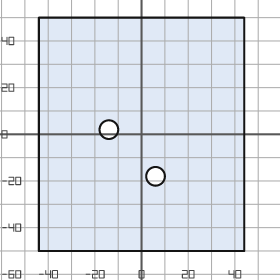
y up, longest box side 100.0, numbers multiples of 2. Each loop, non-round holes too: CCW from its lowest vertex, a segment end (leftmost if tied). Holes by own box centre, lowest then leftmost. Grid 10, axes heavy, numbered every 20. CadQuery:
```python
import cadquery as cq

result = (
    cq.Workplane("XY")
    .moveTo(-44.0, -50.0)
    .lineTo(44.0, -50.0)
    .lineTo(44.0, 50.0)
    .lineTo(-44.0, 50.0)
    .close()
    .moveTo(6.0, -18.0)
    .circle(4.0)
    .moveTo(-14.0, 2.0)
    .circle(4.0)
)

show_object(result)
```